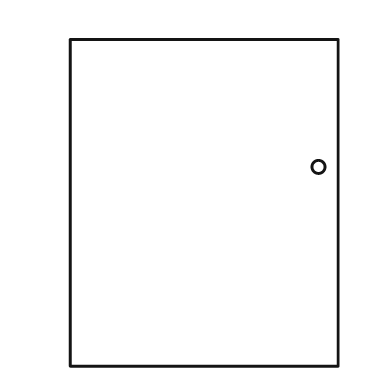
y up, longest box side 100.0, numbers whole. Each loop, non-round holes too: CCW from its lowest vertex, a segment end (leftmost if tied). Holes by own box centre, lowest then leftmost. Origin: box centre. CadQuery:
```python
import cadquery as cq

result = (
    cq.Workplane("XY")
    .moveTo(-41.0, -50.0)
    .lineTo(41.0, -50.0)
    .lineTo(41.0, 50.0)
    .lineTo(-41.0, 50.0)
    .close()
    .moveTo(35.0, 11.0)
    .circle(2.0)
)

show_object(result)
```